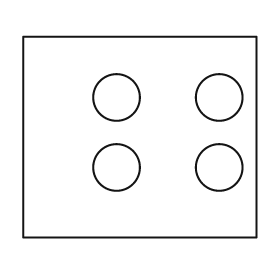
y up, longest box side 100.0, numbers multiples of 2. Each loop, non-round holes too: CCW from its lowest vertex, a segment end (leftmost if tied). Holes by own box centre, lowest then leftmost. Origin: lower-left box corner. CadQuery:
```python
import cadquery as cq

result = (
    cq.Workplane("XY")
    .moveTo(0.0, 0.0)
    .lineTo(100.0, 0.0)
    .lineTo(100.0, 86.0)
    .lineTo(0.0, 86.0)
    .close()
    .moveTo(40.0, 30.0)
    .circle(10.0)
    .moveTo(84.0, 30.0)
    .circle(10.0)
    .moveTo(40.0, 60.0)
    .circle(10.0)
    .moveTo(84.0, 60.0)
    .circle(10.0)
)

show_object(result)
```